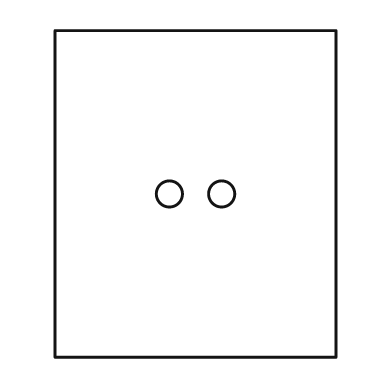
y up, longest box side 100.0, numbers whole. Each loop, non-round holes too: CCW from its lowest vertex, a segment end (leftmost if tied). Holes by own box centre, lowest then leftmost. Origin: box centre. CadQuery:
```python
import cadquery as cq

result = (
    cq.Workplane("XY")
    .moveTo(-43.0, -50.0)
    .lineTo(43.0, -50.0)
    .lineTo(43.0, 50.0)
    .lineTo(-43.0, 50.0)
    .close()
    .moveTo(-8.0, 0.0)
    .circle(4.0)
    .moveTo(8.0, 0.0)
    .circle(4.0)
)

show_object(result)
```